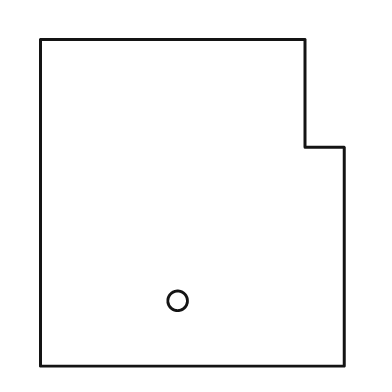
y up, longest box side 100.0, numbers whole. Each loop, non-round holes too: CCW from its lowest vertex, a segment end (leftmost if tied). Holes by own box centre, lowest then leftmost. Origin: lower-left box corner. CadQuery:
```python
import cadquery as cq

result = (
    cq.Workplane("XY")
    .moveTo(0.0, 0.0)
    .lineTo(93.0, 0.0)
    .lineTo(93.0, 67.0)
    .lineTo(81.0, 67.0)
    .lineTo(81.0, 100.0)
    .lineTo(0.0, 100.0)
    .close()
    .moveTo(42.0, 20.0)
    .circle(3.0)
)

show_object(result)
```